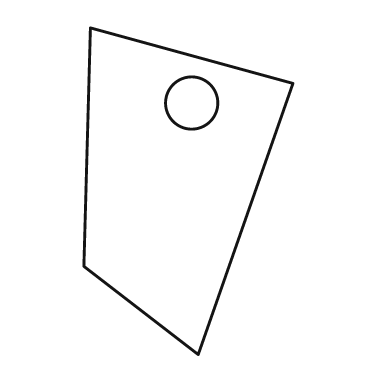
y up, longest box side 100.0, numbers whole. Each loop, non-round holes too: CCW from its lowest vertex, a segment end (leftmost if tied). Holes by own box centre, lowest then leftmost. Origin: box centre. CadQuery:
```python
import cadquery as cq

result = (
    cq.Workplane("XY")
    .moveTo(3.0, -50.0)
    .lineTo(32.0, 33.0)
    .lineTo(-30.0, 50.0)
    .lineTo(-32.0, -23.0)
    .close()
    .moveTo(1.0, 27.0)
    .circle(8.0)
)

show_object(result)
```